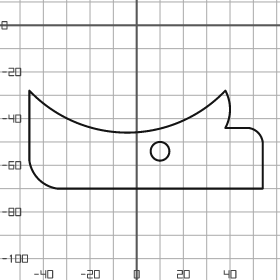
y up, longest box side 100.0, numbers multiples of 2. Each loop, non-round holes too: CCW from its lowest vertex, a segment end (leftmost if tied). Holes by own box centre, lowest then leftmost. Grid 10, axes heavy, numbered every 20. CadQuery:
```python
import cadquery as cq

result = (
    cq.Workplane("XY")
    .moveTo(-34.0, -70.0)
    .lineTo(54.0, -70.0)
    .lineTo(54.0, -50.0)
    .threePointArc((52.0, -46.0), (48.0, -44.0))
    .lineTo(38.0, -44.0)
    .threePointArc((40.0, -36.0), (38.0, -28.0))
    .threePointArc((-4.0, -46.0), (-46.0, -28.0))
    .lineTo(-46.0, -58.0)
    .threePointArc((-42.0, -66.0), (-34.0, -70.0))
    .close()
    .moveTo(10.0, -54.0)
    .circle(4.0)
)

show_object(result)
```